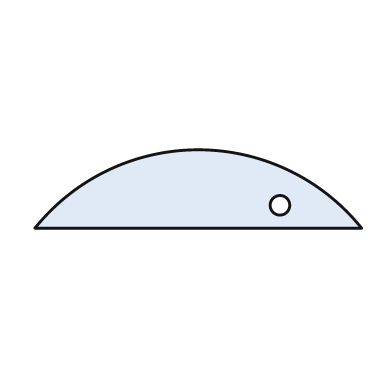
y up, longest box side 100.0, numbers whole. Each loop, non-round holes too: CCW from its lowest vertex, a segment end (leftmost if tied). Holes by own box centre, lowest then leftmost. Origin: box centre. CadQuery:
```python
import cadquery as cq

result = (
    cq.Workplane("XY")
    .moveTo(-50.0, -12.0)
    .lineTo(50.0, -12.0)
    .threePointArc((0.0, 12.0), (-50.0, -12.0))
    .close()
    .moveTo(25.0, -5.0)
    .circle(3.0)
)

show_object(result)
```